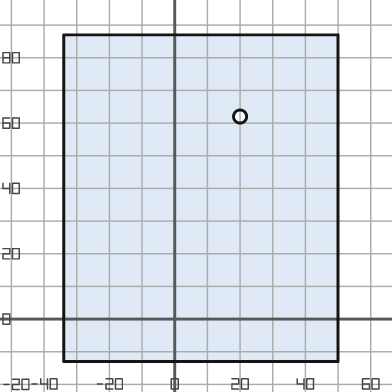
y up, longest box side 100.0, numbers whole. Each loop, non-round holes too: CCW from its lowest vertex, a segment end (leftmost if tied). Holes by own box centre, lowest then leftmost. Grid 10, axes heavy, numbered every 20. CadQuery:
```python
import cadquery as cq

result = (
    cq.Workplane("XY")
    .moveTo(-34.0, -13.0)
    .lineTo(50.0, -13.0)
    .lineTo(50.0, 87.0)
    .lineTo(-34.0, 87.0)
    .close()
    .moveTo(20.0, 62.0)
    .circle(2.0)
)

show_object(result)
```